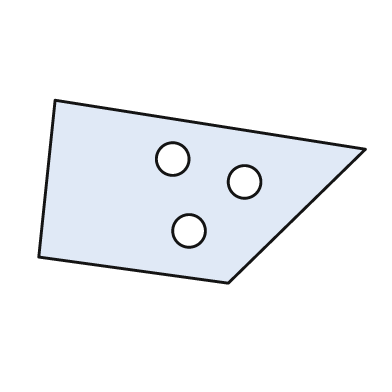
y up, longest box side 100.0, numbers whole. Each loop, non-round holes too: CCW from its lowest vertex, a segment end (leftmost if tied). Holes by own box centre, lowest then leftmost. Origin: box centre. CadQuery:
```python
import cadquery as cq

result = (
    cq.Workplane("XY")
    .moveTo(8.0, -28.0)
    .lineTo(50.0, 13.0)
    .lineTo(-45.0, 28.0)
    .lineTo(-50.0, -20.0)
    .close()
    .moveTo(-4.0, -12.0)
    .circle(5.0)
    .moveTo(13.0, 3.0)
    .circle(5.0)
    .moveTo(-9.0, 10.0)
    .circle(5.0)
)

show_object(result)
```